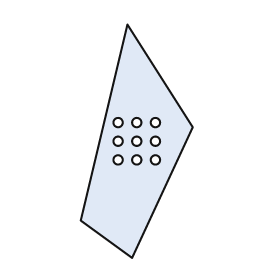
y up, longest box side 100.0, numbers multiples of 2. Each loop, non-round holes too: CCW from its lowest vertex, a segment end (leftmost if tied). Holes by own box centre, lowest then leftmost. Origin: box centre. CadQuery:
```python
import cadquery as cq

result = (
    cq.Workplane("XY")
    .moveTo(-2.0, -50.0)
    .lineTo(24.0, 6.0)
    .lineTo(-4.0, 50.0)
    .lineTo(-24.0, -34.0)
    .close()
    .moveTo(-8.0, -8.0)
    .circle(2.0)
    .moveTo(0.0, -8.0)
    .circle(2.0)
    .moveTo(8.0, -8.0)
    .circle(2.0)
    .moveTo(-8.0, 0.0)
    .circle(2.0)
    .moveTo(0.0, 0.0)
    .circle(2.0)
    .moveTo(8.0, 0.0)
    .circle(2.0)
    .moveTo(-8.0, 8.0)
    .circle(2.0)
    .moveTo(0.0, 8.0)
    .circle(2.0)
    .moveTo(8.0, 8.0)
    .circle(2.0)
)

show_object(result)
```